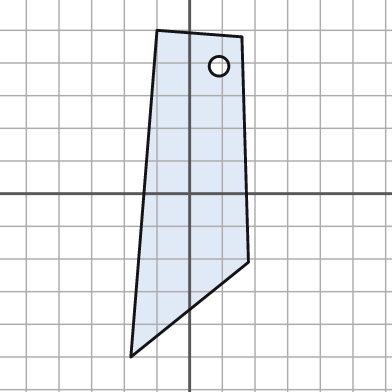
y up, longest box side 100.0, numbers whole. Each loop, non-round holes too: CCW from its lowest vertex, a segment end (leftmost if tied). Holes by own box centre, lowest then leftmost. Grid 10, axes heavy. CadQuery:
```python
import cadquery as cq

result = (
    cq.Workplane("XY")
    .moveTo(-18.0, -50.0)
    .lineTo(18.0, -21.0)
    .lineTo(16.0, 48.0)
    .lineTo(-10.0, 50.0)
    .close()
    .moveTo(9.0, 39.0)
    .circle(3.0)
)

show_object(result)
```